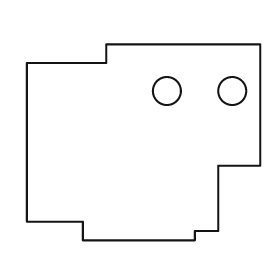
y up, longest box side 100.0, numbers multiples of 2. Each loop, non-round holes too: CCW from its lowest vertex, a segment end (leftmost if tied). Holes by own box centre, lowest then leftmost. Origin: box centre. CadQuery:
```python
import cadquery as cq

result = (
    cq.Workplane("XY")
    .moveTo(-26.0, -42.0)
    .lineTo(22.0, -42.0)
    .lineTo(22.0, -38.0)
    .lineTo(32.0, -38.0)
    .lineTo(32.0, -10.0)
    .lineTo(50.0, -10.0)
    .lineTo(50.0, 42.0)
    .lineTo(-16.0, 42.0)
    .lineTo(-16.0, 34.0)
    .lineTo(-50.0, 34.0)
    .lineTo(-50.0, -34.0)
    .lineTo(-26.0, -34.0)
    .close()
    .moveTo(10.0, 22.0)
    .circle(6.0)
    .moveTo(38.0, 22.0)
    .circle(6.0)
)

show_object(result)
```